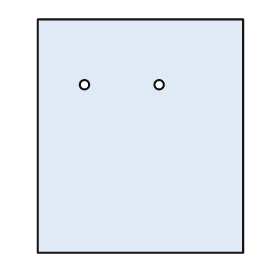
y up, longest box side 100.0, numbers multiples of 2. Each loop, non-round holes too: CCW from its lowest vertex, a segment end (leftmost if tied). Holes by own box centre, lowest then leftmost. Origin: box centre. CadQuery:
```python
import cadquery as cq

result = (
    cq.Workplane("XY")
    .moveTo(-44.0, -50.0)
    .lineTo(44.0, -50.0)
    .lineTo(44.0, 50.0)
    .lineTo(-44.0, 50.0)
    .close()
    .moveTo(-24.0, 22.0)
    .circle(2.0)
    .moveTo(8.0, 22.0)
    .circle(2.0)
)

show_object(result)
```